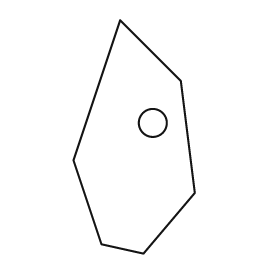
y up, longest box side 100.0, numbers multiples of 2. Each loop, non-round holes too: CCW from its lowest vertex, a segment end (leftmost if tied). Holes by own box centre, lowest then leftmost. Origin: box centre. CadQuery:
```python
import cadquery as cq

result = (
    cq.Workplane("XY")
    .moveTo(4.0, -50.0)
    .lineTo(26.0, -24.0)
    .lineTo(20.0, 24.0)
    .lineTo(-6.0, 50.0)
    .lineTo(-26.0, -10.0)
    .lineTo(-14.0, -46.0)
    .close()
    .moveTo(8.0, 6.0)
    .circle(6.0)
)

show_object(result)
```